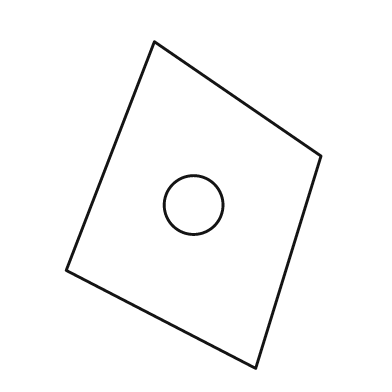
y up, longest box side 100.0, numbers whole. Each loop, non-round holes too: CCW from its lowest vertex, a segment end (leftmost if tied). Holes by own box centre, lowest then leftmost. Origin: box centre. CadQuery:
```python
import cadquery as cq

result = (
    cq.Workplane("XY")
    .moveTo(19.0, -50.0)
    .lineTo(39.0, 15.0)
    .lineTo(-12.0, 50.0)
    .lineTo(-39.0, -20.0)
    .close()
    .moveTo(0.0, 0.0)
    .circle(9.0)
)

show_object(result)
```